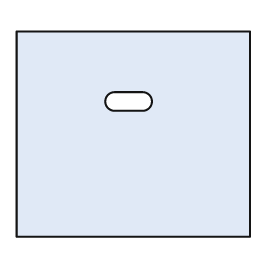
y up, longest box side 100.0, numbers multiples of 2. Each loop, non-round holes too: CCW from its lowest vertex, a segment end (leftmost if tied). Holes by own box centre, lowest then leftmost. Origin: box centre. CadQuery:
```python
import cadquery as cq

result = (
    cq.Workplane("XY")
    .moveTo(-50.0, -44.0)
    .lineTo(50.0, -44.0)
    .lineTo(50.0, 44.0)
    .lineTo(-50.0, 44.0)
    .close()
    .moveTo(-8.0, 10.0)
    .lineTo(4.0, 10.0)
    .threePointArc((8.0, 14.0), (4.0, 18.0))
    .lineTo(-8.0, 18.0)
    .threePointArc((-12.0, 14.0), (-8.0, 10.0))
    .close()
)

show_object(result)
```